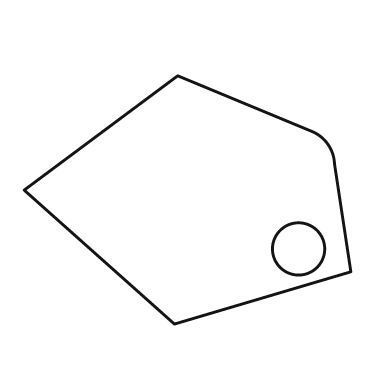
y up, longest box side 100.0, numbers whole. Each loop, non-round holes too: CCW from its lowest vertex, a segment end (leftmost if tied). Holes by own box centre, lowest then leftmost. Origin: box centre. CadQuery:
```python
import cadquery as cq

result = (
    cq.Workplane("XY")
    .moveTo(-4.0, -38.0)
    .lineTo(50.0, -22.0)
    .lineTo(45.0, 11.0)
    .threePointArc((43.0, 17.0), (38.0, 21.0))
    .lineTo(-3.0, 38.0)
    .lineTo(-50.0, 3.0)
    .close()
    .moveTo(34.0, -15.0)
    .circle(8.0)
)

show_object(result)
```